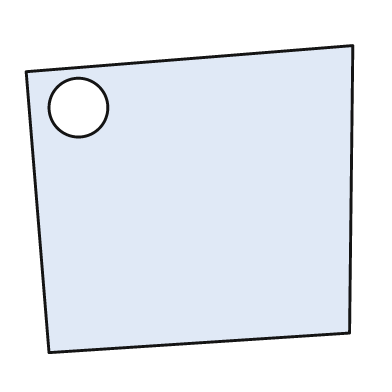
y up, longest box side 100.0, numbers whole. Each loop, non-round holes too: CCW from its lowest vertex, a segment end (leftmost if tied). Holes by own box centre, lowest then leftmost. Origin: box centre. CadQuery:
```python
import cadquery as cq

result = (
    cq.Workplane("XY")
    .moveTo(-43.0, -47.0)
    .lineTo(49.0, -41.0)
    .lineTo(50.0, 47.0)
    .lineTo(-50.0, 39.0)
    .close()
    .moveTo(-34.0, 28.0)
    .circle(9.0)
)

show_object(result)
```